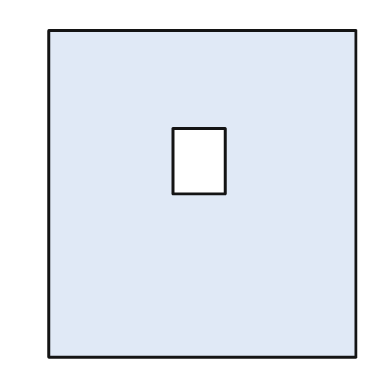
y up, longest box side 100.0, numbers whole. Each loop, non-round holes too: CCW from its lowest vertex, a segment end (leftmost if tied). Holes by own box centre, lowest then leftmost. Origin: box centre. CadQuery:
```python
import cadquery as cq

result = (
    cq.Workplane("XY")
    .moveTo(-47.0, -50.0)
    .lineTo(47.0, -50.0)
    .lineTo(47.0, 50.0)
    .lineTo(-47.0, 50.0)
    .close()
    .moveTo(-9.0, 0.0)
    .lineTo(7.0, 0.0)
    .lineTo(7.0, 20.0)
    .lineTo(-9.0, 20.0)
    .close()
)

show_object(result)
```